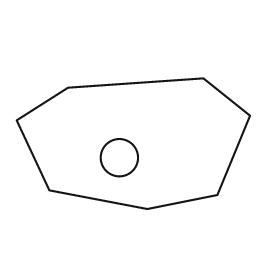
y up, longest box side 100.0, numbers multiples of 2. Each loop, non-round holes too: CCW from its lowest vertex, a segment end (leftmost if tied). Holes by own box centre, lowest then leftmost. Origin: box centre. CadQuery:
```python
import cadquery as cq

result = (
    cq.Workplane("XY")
    .moveTo(6.0, -28.0)
    .lineTo(36.0, -22.0)
    .lineTo(50.0, 12.0)
    .lineTo(30.0, 28.0)
    .lineTo(-28.0, 24.0)
    .lineTo(-50.0, 10.0)
    .lineTo(-36.0, -20.0)
    .close()
    .moveTo(-6.0, -6.0)
    .circle(8.0)
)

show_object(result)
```